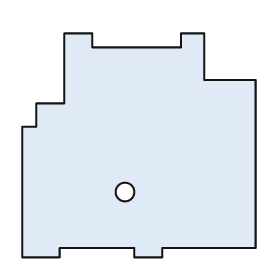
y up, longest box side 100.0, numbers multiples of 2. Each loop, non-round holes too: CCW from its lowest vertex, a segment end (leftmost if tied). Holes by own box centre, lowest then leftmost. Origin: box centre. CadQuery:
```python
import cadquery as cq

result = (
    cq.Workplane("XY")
    .moveTo(-50.0, -48.0)
    .lineTo(-34.0, -48.0)
    .lineTo(-34.0, -44.0)
    .lineTo(-2.0, -44.0)
    .lineTo(-2.0, -48.0)
    .lineTo(10.0, -48.0)
    .lineTo(10.0, -44.0)
    .lineTo(50.0, -44.0)
    .lineTo(50.0, 28.0)
    .lineTo(28.0, 28.0)
    .lineTo(28.0, 48.0)
    .lineTo(18.0, 48.0)
    .lineTo(18.0, 42.0)
    .lineTo(-20.0, 42.0)
    .lineTo(-20.0, 48.0)
    .lineTo(-32.0, 48.0)
    .lineTo(-32.0, 18.0)
    .lineTo(-44.0, 18.0)
    .lineTo(-44.0, 8.0)
    .lineTo(-50.0, 8.0)
    .close()
    .moveTo(-6.0, -20.0)
    .circle(4.0)
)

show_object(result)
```